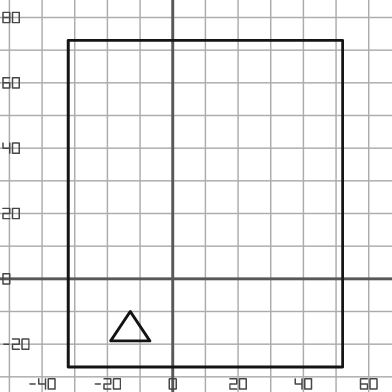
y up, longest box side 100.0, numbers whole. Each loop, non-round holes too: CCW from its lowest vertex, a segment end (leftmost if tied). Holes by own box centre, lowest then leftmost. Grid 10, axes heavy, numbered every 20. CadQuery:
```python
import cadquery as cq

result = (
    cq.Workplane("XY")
    .moveTo(-32.0, -27.0)
    .lineTo(52.0, -27.0)
    .lineTo(52.0, 73.0)
    .lineTo(-32.0, 73.0)
    .close()
    .moveTo(-19.0, -19.0)
    .lineTo(-7.0, -19.0)
    .lineTo(-13.0, -10.0)
    .close()
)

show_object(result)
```